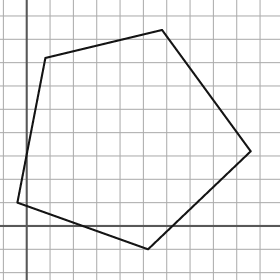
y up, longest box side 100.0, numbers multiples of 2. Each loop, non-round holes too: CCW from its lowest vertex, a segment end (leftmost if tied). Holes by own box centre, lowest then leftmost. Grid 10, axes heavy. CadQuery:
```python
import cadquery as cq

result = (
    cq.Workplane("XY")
    .moveTo(52.0, -10.0)
    .lineTo(96.0, 32.0)
    .lineTo(58.0, 84.0)
    .lineTo(8.0, 72.0)
    .lineTo(-4.0, 10.0)
    .close()
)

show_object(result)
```